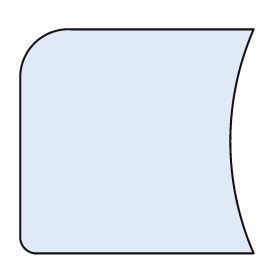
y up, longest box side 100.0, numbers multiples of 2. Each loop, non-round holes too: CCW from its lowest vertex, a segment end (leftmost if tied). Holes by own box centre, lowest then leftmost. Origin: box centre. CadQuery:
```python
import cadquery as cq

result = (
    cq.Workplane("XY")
    .moveTo(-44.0, -48.0)
    .lineTo(50.0, -48.0)
    .threePointArc((40.0, 0.0), (50.0, 48.0))
    .lineTo(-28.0, 48.0)
    .threePointArc((-44.0, 42.0), (-50.0, 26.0))
    .lineTo(-50.0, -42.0)
    .threePointArc((-48.0, -46.0), (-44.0, -48.0))
    .close()
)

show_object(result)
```